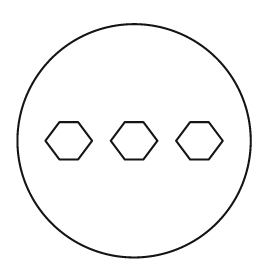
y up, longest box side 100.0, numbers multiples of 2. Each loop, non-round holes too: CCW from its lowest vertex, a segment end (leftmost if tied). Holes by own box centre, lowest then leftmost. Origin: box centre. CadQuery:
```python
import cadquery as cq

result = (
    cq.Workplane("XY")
    .moveTo(0.0, 0.0)
    .circle(50.0)
    .moveTo(-32.0, -8.0)
    .lineTo(-24.0, -8.0)
    .lineTo(-18.0, 0.0)
    .lineTo(-24.0, 8.0)
    .lineTo(-32.0, 8.0)
    .lineTo(-38.0, 0.0)
    .close()
    .moveTo(-4.0, -8.0)
    .lineTo(4.0, -8.0)
    .lineTo(10.0, 0.0)
    .lineTo(4.0, 8.0)
    .lineTo(-4.0, 8.0)
    .lineTo(-10.0, 0.0)
    .close()
    .moveTo(24.0, -8.0)
    .lineTo(32.0, -8.0)
    .lineTo(38.0, 0.0)
    .lineTo(32.0, 8.0)
    .lineTo(24.0, 8.0)
    .lineTo(18.0, 0.0)
    .close()
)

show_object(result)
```